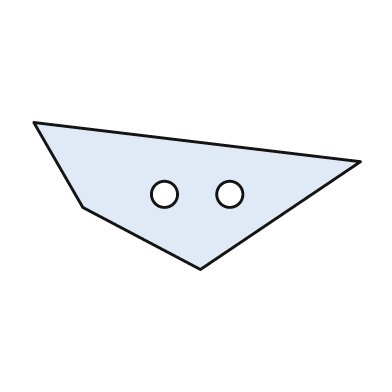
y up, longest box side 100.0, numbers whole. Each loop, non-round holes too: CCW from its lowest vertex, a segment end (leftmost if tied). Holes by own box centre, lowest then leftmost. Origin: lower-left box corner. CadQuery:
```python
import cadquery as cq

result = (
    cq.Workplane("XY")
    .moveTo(51.0, 0.0)
    .lineTo(100.0, 33.0)
    .lineTo(0.0, 45.0)
    .lineTo(15.0, 19.0)
    .close()
    .moveTo(40.0, 23.0)
    .circle(4.0)
    .moveTo(60.0, 23.0)
    .circle(4.0)
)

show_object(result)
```